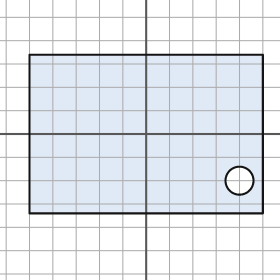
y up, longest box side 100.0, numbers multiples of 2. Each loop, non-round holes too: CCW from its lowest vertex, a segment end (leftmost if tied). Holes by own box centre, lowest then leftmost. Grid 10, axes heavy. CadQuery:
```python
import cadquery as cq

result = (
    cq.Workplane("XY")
    .moveTo(-50.0, -34.0)
    .lineTo(50.0, -34.0)
    .lineTo(50.0, 34.0)
    .lineTo(-50.0, 34.0)
    .close()
    .moveTo(40.0, -20.0)
    .circle(6.0)
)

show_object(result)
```